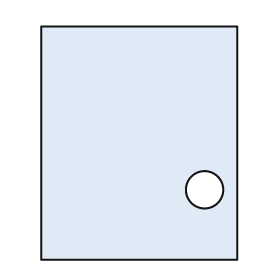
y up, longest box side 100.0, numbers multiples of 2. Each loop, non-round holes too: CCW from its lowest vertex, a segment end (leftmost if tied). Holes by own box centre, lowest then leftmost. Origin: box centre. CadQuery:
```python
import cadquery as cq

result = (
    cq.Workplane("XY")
    .moveTo(-42.0, -50.0)
    .lineTo(42.0, -50.0)
    .lineTo(42.0, 50.0)
    .lineTo(-42.0, 50.0)
    .close()
    .moveTo(28.0, -20.0)
    .circle(8.0)
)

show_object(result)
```